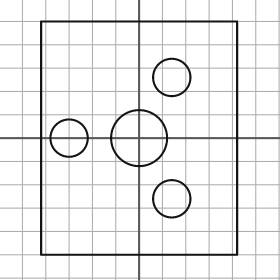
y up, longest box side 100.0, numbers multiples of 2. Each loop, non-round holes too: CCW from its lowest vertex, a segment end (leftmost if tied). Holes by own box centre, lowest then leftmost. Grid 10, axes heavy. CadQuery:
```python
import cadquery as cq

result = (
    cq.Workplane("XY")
    .moveTo(-42.0, -50.0)
    .lineTo(42.0, -50.0)
    .lineTo(42.0, 50.0)
    .lineTo(-42.0, 50.0)
    .close()
    .moveTo(14.0, -26.0)
    .circle(8.0)
    .moveTo(-30.0, 0.0)
    .circle(8.0)
    .moveTo(0.0, 0.0)
    .circle(12.0)
    .moveTo(14.0, 26.0)
    .circle(8.0)
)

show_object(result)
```